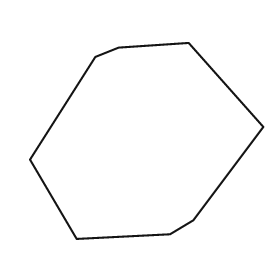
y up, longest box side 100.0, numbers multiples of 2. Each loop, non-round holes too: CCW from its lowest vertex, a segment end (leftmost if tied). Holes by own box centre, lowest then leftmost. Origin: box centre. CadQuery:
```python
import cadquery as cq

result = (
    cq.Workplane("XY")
    .moveTo(-30.0, -42.0)
    .lineTo(10.0, -40.0)
    .lineTo(20.0, -34.0)
    .lineTo(50.0, 6.0)
    .lineTo(18.0, 42.0)
    .lineTo(-12.0, 40.0)
    .lineTo(-22.0, 36.0)
    .lineTo(-50.0, -8.0)
    .close()
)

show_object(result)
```